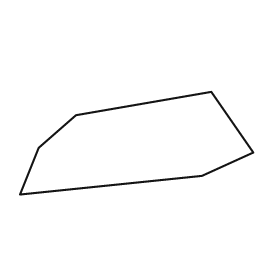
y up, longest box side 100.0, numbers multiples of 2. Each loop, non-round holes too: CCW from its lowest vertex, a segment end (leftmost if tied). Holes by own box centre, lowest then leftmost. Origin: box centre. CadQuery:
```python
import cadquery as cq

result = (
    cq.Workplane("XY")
    .moveTo(-50.0, -22.0)
    .lineTo(28.0, -14.0)
    .lineTo(50.0, -4.0)
    .lineTo(32.0, 22.0)
    .lineTo(-26.0, 12.0)
    .lineTo(-42.0, -2.0)
    .close()
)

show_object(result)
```